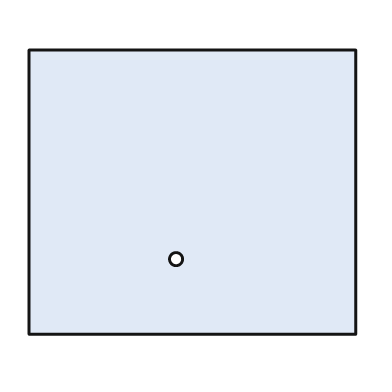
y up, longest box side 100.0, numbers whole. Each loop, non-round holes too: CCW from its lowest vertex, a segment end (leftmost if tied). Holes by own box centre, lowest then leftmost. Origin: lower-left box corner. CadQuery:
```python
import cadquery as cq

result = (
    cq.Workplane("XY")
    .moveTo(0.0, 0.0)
    .lineTo(100.0, 0.0)
    .lineTo(100.0, 87.0)
    .lineTo(0.0, 87.0)
    .close()
    .moveTo(45.0, 23.0)
    .circle(2.0)
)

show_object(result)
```